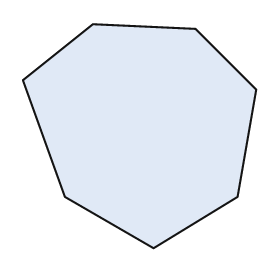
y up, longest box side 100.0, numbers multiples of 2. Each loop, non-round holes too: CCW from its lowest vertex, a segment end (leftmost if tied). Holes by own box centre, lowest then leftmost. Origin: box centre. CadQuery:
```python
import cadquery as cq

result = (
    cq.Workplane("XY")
    .moveTo(6.0, -48.0)
    .lineTo(42.0, -26.0)
    .lineTo(50.0, 20.0)
    .lineTo(24.0, 46.0)
    .lineTo(-20.0, 48.0)
    .lineTo(-50.0, 24.0)
    .lineTo(-32.0, -26.0)
    .close()
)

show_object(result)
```